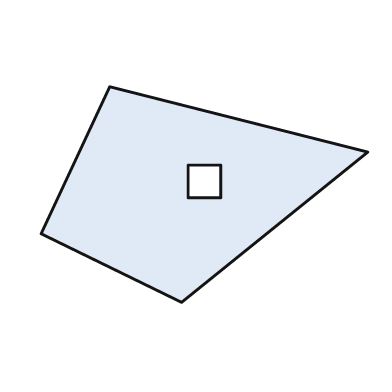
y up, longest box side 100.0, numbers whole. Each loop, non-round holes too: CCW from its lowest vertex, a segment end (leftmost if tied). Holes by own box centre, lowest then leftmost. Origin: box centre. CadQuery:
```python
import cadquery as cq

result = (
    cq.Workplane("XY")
    .moveTo(-7.0, -33.0)
    .lineTo(50.0, 13.0)
    .lineTo(-29.0, 33.0)
    .lineTo(-50.0, -12.0)
    .close()
    .moveTo(-5.0, -1.0)
    .lineTo(5.0, -1.0)
    .lineTo(5.0, 9.0)
    .lineTo(-5.0, 9.0)
    .close()
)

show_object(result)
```